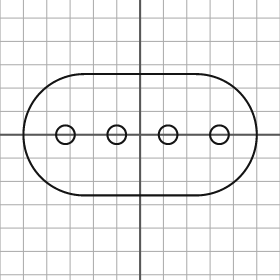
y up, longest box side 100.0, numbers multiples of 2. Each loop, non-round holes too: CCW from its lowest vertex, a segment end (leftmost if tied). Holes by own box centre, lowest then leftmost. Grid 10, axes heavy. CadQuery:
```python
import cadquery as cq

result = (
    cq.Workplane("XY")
    .moveTo(-24.0, -26.0)
    .lineTo(24.0, -26.0)
    .threePointArc((50.0, 0.0), (24.0, 26.0))
    .lineTo(-24.0, 26.0)
    .threePointArc((-50.0, 0.0), (-24.0, -26.0))
    .close()
    .moveTo(-32.0, 0.0)
    .circle(4.0)
    .moveTo(-10.0, 0.0)
    .circle(4.0)
    .moveTo(12.0, 0.0)
    .circle(4.0)
    .moveTo(34.0, 0.0)
    .circle(4.0)
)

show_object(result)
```